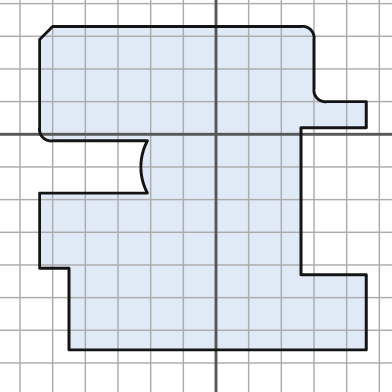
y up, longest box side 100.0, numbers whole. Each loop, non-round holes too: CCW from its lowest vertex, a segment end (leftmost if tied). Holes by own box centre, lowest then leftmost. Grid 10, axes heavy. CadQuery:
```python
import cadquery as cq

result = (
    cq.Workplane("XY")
    .moveTo(-45.0, -66.0)
    .lineTo(46.0, -66.0)
    .lineTo(46.0, -43.0)
    .lineTo(26.0, -43.0)
    .lineTo(26.0, 2.0)
    .lineTo(46.0, 2.0)
    .lineTo(46.0, 10.0)
    .lineTo(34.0, 10.0)
    .threePointArc((31.0, 11.0), (30.0, 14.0))
    .lineTo(30.0, 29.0)
    .threePointArc((29.0, 32.0), (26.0, 33.0))
    .lineTo(-50.0, 33.0)
    .lineTo(-54.0, 29.0)
    .lineTo(-54.0, 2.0)
    .threePointArc((-53.0, -1.0), (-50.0, -2.0))
    .lineTo(-21.0, -2.0)
    .threePointArc((-23.0, -10.0), (-21.0, -18.0))
    .lineTo(-54.0, -18.0)
    .lineTo(-54.0, -41.0)
    .lineTo(-45.0, -41.0)
    .close()
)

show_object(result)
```